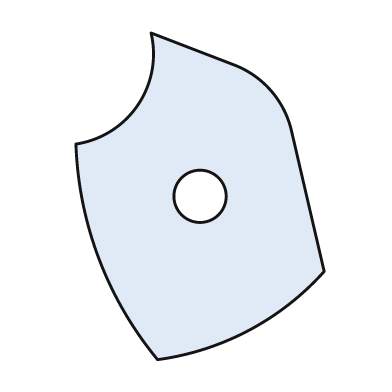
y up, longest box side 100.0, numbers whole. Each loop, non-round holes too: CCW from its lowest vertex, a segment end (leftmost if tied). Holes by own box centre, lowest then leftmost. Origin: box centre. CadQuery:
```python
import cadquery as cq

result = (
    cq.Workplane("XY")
    .moveTo(-13.0, -50.0)
    .threePointArc((15.0, -41.0), (38.0, -23.0))
    .lineTo(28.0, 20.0)
    .threePointArc((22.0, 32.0), (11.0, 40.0))
    .lineTo(-15.0, 50.0)
    .threePointArc((-19.0, 28.0), (-38.0, 16.0))
    .threePointArc((-31.0, -19.0), (-13.0, -50.0))
    .close()
    .moveTo(0.0, 0.0)
    .circle(8.0)
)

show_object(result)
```